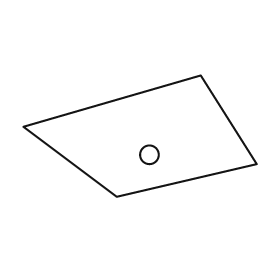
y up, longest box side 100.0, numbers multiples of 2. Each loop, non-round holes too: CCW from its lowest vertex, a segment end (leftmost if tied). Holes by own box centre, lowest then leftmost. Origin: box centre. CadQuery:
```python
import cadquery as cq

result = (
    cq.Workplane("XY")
    .moveTo(-10.0, -26.0)
    .lineTo(50.0, -12.0)
    .lineTo(26.0, 26.0)
    .lineTo(-50.0, 4.0)
    .close()
    .moveTo(4.0, -8.0)
    .circle(4.0)
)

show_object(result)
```